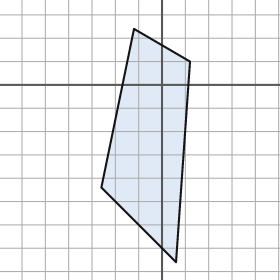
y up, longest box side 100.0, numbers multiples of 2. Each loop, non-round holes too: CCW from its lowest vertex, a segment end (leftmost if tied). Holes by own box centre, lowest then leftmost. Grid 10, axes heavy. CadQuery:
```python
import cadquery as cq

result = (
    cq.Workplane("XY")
    .moveTo(6.0, -76.0)
    .lineTo(12.0, 10.0)
    .lineTo(-12.0, 24.0)
    .lineTo(-26.0, -44.0)
    .close()
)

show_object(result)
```